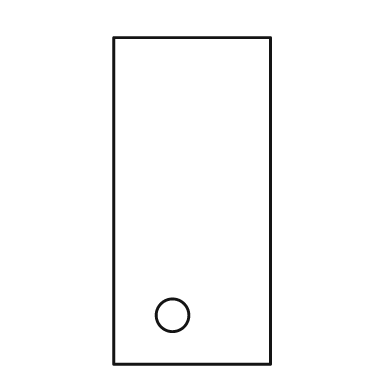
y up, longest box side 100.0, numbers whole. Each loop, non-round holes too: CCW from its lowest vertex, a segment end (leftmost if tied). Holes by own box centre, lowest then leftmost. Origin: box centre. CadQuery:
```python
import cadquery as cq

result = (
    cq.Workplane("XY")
    .moveTo(-24.0, -50.0)
    .lineTo(24.0, -50.0)
    .lineTo(24.0, 50.0)
    .lineTo(-24.0, 50.0)
    .close()
    .moveTo(-6.0, -35.0)
    .circle(5.0)
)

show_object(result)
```